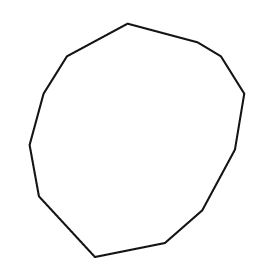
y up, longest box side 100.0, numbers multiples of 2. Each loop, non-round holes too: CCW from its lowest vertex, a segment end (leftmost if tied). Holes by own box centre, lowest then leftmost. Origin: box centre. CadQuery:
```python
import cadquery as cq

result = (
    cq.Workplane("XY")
    .moveTo(-18.0, -50.0)
    .lineTo(12.0, -44.0)
    .lineTo(28.0, -30.0)
    .lineTo(42.0, -4.0)
    .lineTo(46.0, 20.0)
    .lineTo(36.0, 36.0)
    .lineTo(26.0, 42.0)
    .lineTo(-4.0, 50.0)
    .lineTo(-30.0, 36.0)
    .lineTo(-40.0, 20.0)
    .lineTo(-46.0, -2.0)
    .lineTo(-42.0, -24.0)
    .close()
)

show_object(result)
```